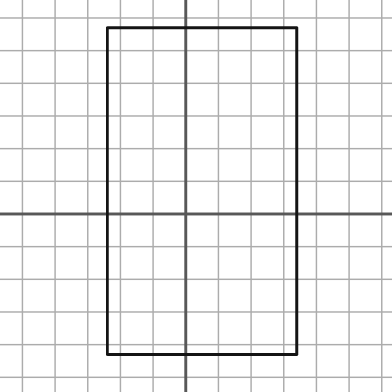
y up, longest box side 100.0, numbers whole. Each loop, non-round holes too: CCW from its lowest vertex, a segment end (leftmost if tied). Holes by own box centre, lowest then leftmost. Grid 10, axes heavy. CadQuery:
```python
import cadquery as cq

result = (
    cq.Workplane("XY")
    .moveTo(-24.0, -43.0)
    .lineTo(34.0, -43.0)
    .lineTo(34.0, 57.0)
    .lineTo(-24.0, 57.0)
    .close()
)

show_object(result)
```